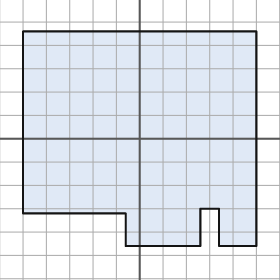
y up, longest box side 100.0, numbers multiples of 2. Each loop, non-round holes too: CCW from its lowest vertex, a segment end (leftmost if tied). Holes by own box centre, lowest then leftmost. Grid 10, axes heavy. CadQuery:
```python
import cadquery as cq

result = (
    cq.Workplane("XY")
    .moveTo(-6.0, -46.0)
    .lineTo(26.0, -46.0)
    .lineTo(26.0, -30.0)
    .lineTo(34.0, -30.0)
    .lineTo(34.0, -46.0)
    .lineTo(50.0, -46.0)
    .lineTo(50.0, 46.0)
    .lineTo(-50.0, 46.0)
    .lineTo(-50.0, -32.0)
    .lineTo(-6.0, -32.0)
    .close()
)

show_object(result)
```